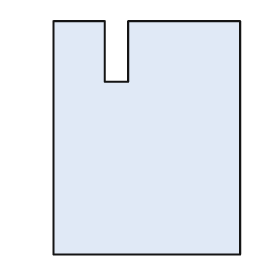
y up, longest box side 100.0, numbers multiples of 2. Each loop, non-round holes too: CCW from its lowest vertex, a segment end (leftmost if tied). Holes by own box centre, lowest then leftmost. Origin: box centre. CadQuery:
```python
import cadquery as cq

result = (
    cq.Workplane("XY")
    .moveTo(-40.0, -50.0)
    .lineTo(40.0, -50.0)
    .lineTo(40.0, 50.0)
    .lineTo(-8.0, 50.0)
    .lineTo(-8.0, 24.0)
    .lineTo(-18.0, 24.0)
    .lineTo(-18.0, 50.0)
    .lineTo(-40.0, 50.0)
    .close()
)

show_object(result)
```